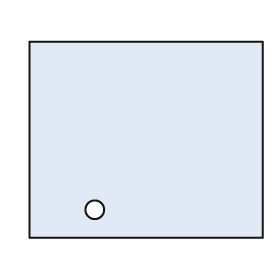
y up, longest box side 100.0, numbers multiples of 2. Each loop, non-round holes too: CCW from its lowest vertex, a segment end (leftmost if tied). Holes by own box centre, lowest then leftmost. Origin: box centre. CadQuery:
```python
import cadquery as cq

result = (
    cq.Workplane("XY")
    .moveTo(-50.0, -42.0)
    .lineTo(50.0, -42.0)
    .lineTo(50.0, 42.0)
    .lineTo(-50.0, 42.0)
    .close()
    .moveTo(-22.0, -30.0)
    .circle(4.0)
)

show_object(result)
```